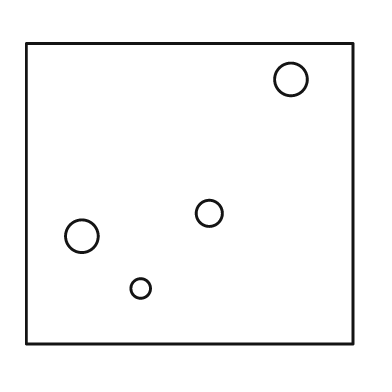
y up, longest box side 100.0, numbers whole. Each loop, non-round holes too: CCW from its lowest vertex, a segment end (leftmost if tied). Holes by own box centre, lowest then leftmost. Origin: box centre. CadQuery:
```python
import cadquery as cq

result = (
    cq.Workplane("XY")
    .moveTo(-50.0, -46.0)
    .lineTo(50.0, -46.0)
    .lineTo(50.0, 46.0)
    .lineTo(-50.0, 46.0)
    .close()
    .moveTo(-15.0, -29.0)
    .circle(3.0)
    .moveTo(-33.0, -13.0)
    .circle(5.0)
    .moveTo(6.0, -6.0)
    .circle(4.0)
    .moveTo(31.0, 35.0)
    .circle(5.0)
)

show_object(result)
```